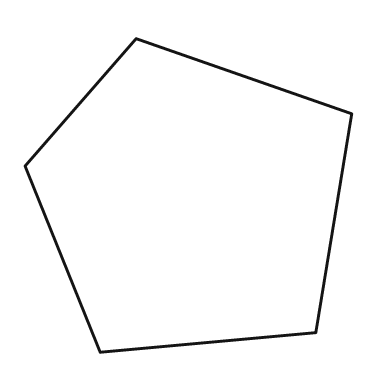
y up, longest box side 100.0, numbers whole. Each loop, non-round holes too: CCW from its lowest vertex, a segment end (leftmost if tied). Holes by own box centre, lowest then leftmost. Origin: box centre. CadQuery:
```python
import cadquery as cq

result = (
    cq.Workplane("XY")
    .moveTo(-27.0, -48.0)
    .lineTo(39.0, -42.0)
    .lineTo(50.0, 25.0)
    .lineTo(-16.0, 48.0)
    .lineTo(-50.0, 9.0)
    .close()
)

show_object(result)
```